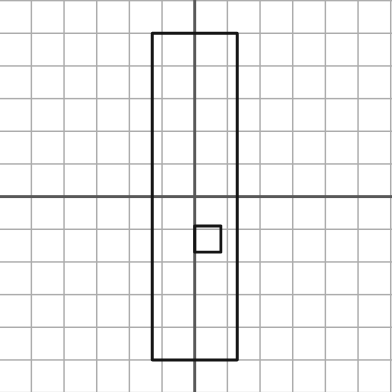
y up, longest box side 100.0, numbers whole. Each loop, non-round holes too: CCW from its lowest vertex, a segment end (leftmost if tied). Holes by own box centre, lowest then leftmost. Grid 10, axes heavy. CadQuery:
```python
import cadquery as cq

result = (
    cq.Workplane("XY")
    .moveTo(-13.0, -50.0)
    .lineTo(13.0, -50.0)
    .lineTo(13.0, 50.0)
    .lineTo(-13.0, 50.0)
    .close()
    .moveTo(0.0, -17.0)
    .lineTo(8.0, -17.0)
    .lineTo(8.0, -9.0)
    .lineTo(0.0, -9.0)
    .close()
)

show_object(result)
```